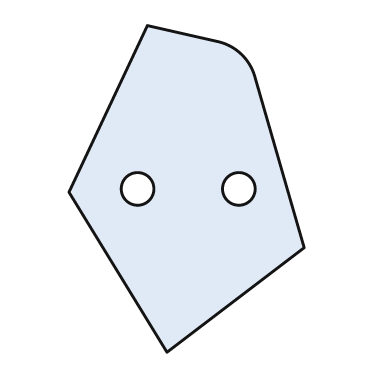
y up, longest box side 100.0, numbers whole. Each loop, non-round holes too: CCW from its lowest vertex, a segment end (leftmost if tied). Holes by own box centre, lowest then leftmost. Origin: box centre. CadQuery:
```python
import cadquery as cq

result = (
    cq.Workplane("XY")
    .moveTo(-6.0, -50.0)
    .lineTo(36.0, -18.0)
    .lineTo(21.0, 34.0)
    .threePointArc((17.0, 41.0), (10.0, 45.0))
    .lineTo(-12.0, 50.0)
    .lineTo(-36.0, -1.0)
    .close()
    .moveTo(-15.0, 0.0)
    .circle(5.0)
    .moveTo(16.0, 0.0)
    .circle(5.0)
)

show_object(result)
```